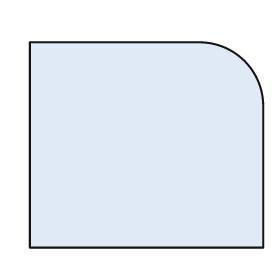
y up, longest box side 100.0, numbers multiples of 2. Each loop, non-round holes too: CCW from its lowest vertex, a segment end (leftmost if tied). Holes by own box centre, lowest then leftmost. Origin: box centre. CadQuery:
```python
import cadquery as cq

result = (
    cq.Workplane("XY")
    .moveTo(-50.0, -44.0)
    .lineTo(50.0, -44.0)
    .lineTo(50.0, 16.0)
    .threePointArc((42.0, 36.0), (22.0, 44.0))
    .lineTo(-50.0, 44.0)
    .close()
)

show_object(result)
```